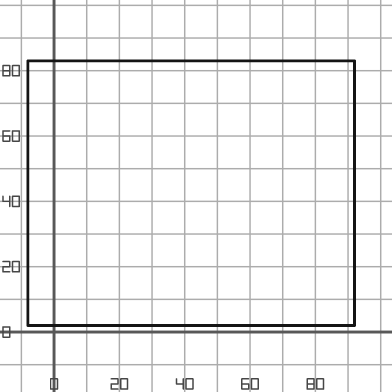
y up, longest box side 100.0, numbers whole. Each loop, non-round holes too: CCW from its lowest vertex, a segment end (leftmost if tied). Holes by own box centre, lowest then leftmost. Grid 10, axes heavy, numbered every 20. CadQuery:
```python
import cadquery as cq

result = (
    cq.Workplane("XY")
    .moveTo(-8.0, 2.0)
    .lineTo(92.0, 2.0)
    .lineTo(92.0, 83.0)
    .lineTo(-8.0, 83.0)
    .close()
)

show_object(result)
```